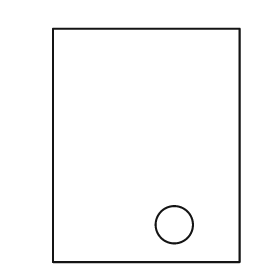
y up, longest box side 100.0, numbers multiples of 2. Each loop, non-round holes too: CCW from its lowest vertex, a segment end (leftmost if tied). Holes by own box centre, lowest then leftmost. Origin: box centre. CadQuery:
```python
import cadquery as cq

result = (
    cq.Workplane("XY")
    .moveTo(-40.0, -50.0)
    .lineTo(40.0, -50.0)
    .lineTo(40.0, 50.0)
    .lineTo(-40.0, 50.0)
    .close()
    .moveTo(12.0, -34.0)
    .circle(8.0)
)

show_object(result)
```